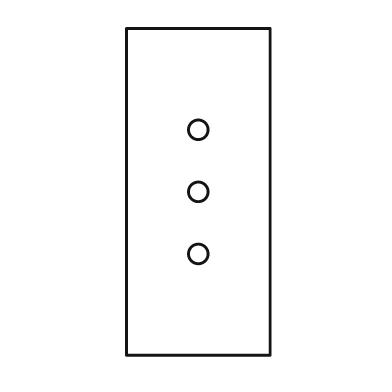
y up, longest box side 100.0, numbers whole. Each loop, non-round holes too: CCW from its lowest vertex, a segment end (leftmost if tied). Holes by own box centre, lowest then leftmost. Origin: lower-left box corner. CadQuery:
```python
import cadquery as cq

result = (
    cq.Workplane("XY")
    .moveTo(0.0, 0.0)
    .lineTo(44.0, 0.0)
    .lineTo(44.0, 100.0)
    .lineTo(0.0, 100.0)
    .close()
    .moveTo(22.0, 31.0)
    .circle(3.0)
    .moveTo(22.0, 50.0)
    .circle(3.0)
    .moveTo(22.0, 69.0)
    .circle(3.0)
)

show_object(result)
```